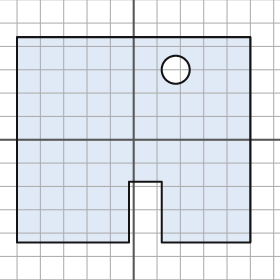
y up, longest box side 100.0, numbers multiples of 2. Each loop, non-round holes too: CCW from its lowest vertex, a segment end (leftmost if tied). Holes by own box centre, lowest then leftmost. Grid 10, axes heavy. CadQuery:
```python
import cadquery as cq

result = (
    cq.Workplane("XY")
    .moveTo(-50.0, -44.0)
    .lineTo(-2.0, -44.0)
    .lineTo(-2.0, -18.0)
    .lineTo(12.0, -18.0)
    .lineTo(12.0, -44.0)
    .lineTo(50.0, -44.0)
    .lineTo(50.0, 44.0)
    .lineTo(-50.0, 44.0)
    .close()
    .moveTo(18.0, 30.0)
    .circle(6.0)
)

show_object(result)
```